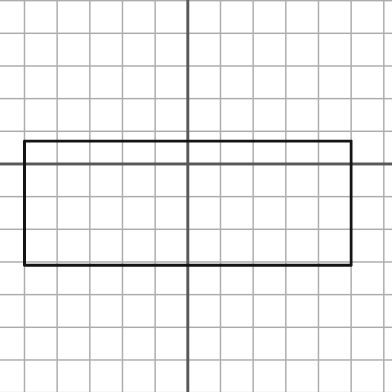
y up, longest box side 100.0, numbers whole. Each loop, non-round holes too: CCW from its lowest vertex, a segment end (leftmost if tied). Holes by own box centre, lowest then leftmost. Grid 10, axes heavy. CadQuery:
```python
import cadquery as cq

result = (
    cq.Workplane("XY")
    .moveTo(-50.0, -31.0)
    .lineTo(50.0, -31.0)
    .lineTo(50.0, 7.0)
    .lineTo(-50.0, 7.0)
    .close()
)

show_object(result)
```